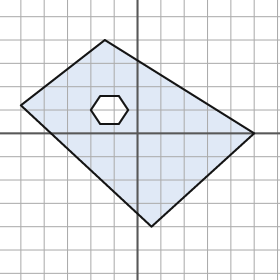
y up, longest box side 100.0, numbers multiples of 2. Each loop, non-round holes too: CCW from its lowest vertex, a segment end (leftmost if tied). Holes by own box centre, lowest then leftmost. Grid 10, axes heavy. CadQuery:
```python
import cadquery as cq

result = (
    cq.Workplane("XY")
    .moveTo(6.0, -40.0)
    .lineTo(50.0, 0.0)
    .lineTo(-14.0, 40.0)
    .lineTo(-50.0, 12.0)
    .close()
    .moveTo(-16.0, 4.0)
    .lineTo(-8.0, 4.0)
    .lineTo(-4.0, 10.0)
    .lineTo(-8.0, 16.0)
    .lineTo(-16.0, 16.0)
    .lineTo(-20.0, 10.0)
    .close()
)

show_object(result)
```